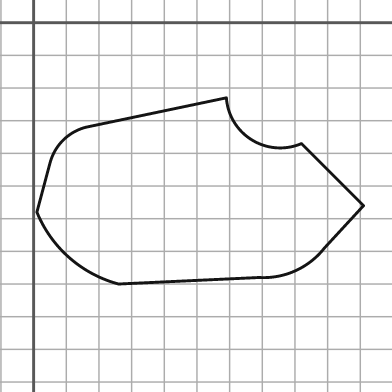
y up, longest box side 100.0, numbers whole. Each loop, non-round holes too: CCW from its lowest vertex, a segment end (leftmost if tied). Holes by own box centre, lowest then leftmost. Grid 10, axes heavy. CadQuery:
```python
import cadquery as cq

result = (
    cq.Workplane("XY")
    .moveTo(26.0, -80.0)
    .lineTo(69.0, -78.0)
    .threePointArc((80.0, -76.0), (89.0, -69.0))
    .lineTo(101.0, -56.0)
    .lineTo(82.0, -37.0)
    .threePointArc((67.0, -36.0), (59.0, -23.0))
    .lineTo(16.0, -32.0)
    .threePointArc((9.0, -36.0), (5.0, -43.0))
    .lineTo(1.0, -58.0)
    .threePointArc((11.0, -72.0), (26.0, -80.0))
    .close()
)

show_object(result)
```